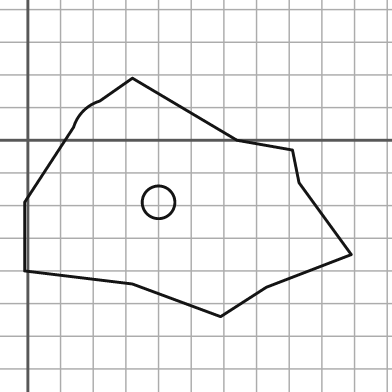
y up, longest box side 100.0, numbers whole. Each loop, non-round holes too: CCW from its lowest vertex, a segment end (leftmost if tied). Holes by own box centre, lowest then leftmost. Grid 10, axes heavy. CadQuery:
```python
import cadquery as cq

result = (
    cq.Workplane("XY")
    .moveTo(59.0, -54.0)
    .lineTo(73.0, -45.0)
    .lineTo(99.0, -35.0)
    .lineTo(83.0, -13.0)
    .lineTo(81.0, -3.0)
    .lineTo(64.0, 0.0)
    .lineTo(32.0, 19.0)
    .lineTo(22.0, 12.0)
    .threePointArc((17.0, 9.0), (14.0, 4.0))
    .lineTo(-1.0, -19.0)
    .lineTo(-1.0, -40.0)
    .lineTo(32.0, -44.0)
    .close()
    .moveTo(40.0, -19.0)
    .circle(5.0)
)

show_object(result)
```